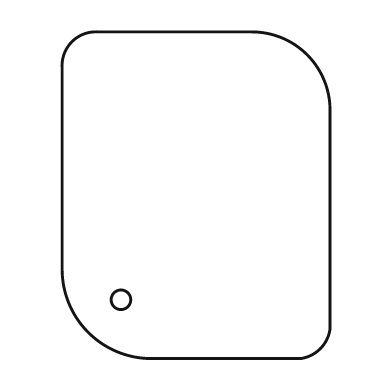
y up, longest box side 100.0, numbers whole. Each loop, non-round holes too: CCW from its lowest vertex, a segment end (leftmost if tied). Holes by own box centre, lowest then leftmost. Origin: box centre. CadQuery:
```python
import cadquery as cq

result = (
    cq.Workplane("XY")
    .moveTo(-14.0, -50.0)
    .lineTo(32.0, -50.0)
    .threePointArc((38.0, -47.0), (41.0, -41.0))
    .lineTo(41.0, 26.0)
    .threePointArc((34.0, 43.0), (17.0, 50.0))
    .lineTo(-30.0, 50.0)
    .threePointArc((-38.0, 47.0), (-41.0, 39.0))
    .lineTo(-41.0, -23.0)
    .threePointArc((-33.0, -42.0), (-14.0, -50.0))
    .close()
    .moveTo(-23.0, -32.0)
    .circle(3.0)
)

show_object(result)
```